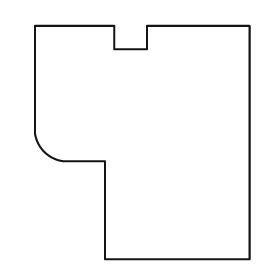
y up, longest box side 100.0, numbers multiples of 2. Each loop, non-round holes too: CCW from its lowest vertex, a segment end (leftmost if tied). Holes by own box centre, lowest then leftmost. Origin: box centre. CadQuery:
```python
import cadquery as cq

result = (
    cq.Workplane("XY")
    .moveTo(-16.0, -50.0)
    .lineTo(46.0, -50.0)
    .lineTo(46.0, 50.0)
    .lineTo(2.0, 50.0)
    .lineTo(2.0, 40.0)
    .lineTo(-12.0, 40.0)
    .lineTo(-12.0, 50.0)
    .lineTo(-46.0, 50.0)
    .lineTo(-46.0, 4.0)
    .threePointArc((-42.0, -4.0), (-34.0, -8.0))
    .lineTo(-16.0, -8.0)
    .close()
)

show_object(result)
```